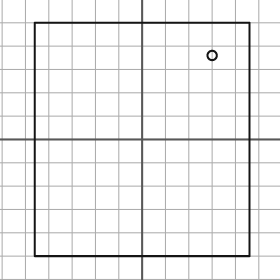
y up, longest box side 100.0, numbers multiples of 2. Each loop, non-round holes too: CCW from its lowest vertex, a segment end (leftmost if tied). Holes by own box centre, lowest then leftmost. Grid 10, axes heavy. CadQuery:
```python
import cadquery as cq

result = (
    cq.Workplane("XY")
    .moveTo(-46.0, -50.0)
    .lineTo(46.0, -50.0)
    .lineTo(46.0, 50.0)
    .lineTo(-46.0, 50.0)
    .close()
    .moveTo(30.0, 36.0)
    .circle(2.0)
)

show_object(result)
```